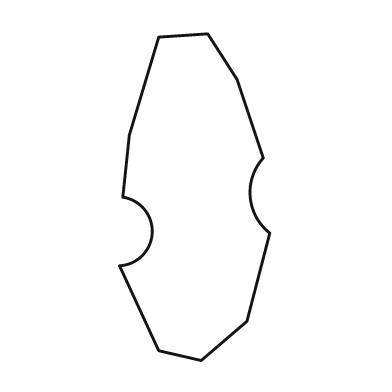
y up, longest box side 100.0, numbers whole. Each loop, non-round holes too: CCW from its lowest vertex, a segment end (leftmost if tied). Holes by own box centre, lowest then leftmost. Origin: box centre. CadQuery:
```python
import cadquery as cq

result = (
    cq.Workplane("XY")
    .moveTo(2.0, -50.0)
    .lineTo(16.0, -38.0)
    .lineTo(23.0, -11.0)
    .threePointArc((17.0, 0.0), (21.0, 12.0))
    .lineTo(13.0, 36.0)
    .lineTo(4.0, 50.0)
    .lineTo(-11.0, 49.0)
    .lineTo(-20.0, 19.0)
    .lineTo(-22.0, 0.0)
    .threePointArc((-13.0, -11.0), (-23.0, -21.0))
    .lineTo(-11.0, -47.0)
    .close()
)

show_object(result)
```